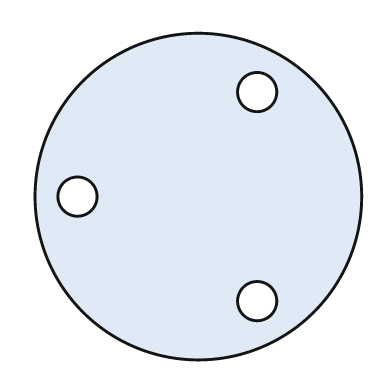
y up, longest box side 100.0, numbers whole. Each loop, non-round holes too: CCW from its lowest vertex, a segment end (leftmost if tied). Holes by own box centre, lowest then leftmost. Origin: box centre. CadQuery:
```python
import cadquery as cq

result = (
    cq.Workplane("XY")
    .moveTo(0.0, 0.0)
    .circle(50.0)
    .moveTo(18.0, -32.0)
    .circle(6.0)
    .moveTo(-37.0, 0.0)
    .circle(6.0)
    .moveTo(18.0, 32.0)
    .circle(6.0)
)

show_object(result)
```